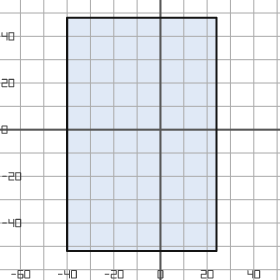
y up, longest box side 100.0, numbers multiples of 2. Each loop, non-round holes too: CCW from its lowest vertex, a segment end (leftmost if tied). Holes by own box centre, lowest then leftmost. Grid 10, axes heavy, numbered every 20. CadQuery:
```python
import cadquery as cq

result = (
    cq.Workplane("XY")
    .moveTo(-40.0, -52.0)
    .lineTo(24.0, -52.0)
    .lineTo(24.0, 48.0)
    .lineTo(-40.0, 48.0)
    .close()
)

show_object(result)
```